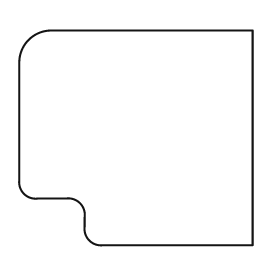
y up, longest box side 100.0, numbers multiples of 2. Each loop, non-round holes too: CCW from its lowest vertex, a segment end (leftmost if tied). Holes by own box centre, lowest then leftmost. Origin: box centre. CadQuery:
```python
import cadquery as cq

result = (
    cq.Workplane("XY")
    .moveTo(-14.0, -46.0)
    .lineTo(50.0, -46.0)
    .lineTo(50.0, 46.0)
    .lineTo(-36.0, 46.0)
    .threePointArc((-46.0, 42.0), (-50.0, 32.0))
    .lineTo(-50.0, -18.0)
    .threePointArc((-48.0, -24.0), (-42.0, -26.0))
    .lineTo(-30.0, -26.0)
    .threePointArc((-24.0, -28.0), (-22.0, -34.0))
    .lineTo(-22.0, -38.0)
    .threePointArc((-20.0, -44.0), (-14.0, -46.0))
    .close()
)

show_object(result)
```